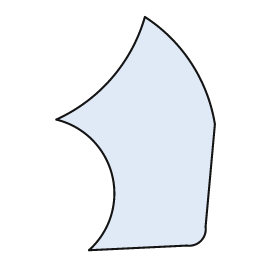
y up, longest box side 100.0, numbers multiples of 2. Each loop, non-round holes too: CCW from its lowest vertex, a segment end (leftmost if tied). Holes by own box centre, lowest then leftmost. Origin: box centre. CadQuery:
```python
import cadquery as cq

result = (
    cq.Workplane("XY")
    .moveTo(-20.0, -50.0)
    .lineTo(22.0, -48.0)
    .threePointArc((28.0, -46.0), (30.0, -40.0))
    .lineTo(34.0, 4.0)
    .threePointArc((24.0, 30.0), (4.0, 50.0))
    .threePointArc((-10.0, 24.0), (-34.0, 6.0))
    .threePointArc((-10.0, -18.0), (-20.0, -50.0))
    .close()
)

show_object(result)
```